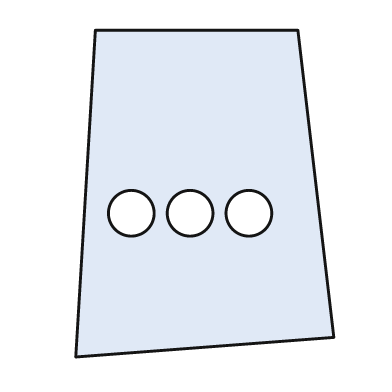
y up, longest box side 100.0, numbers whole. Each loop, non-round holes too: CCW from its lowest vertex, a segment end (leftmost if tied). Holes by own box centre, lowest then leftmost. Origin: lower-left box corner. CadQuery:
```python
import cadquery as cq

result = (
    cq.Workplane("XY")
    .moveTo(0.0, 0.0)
    .lineTo(79.0, 6.0)
    .lineTo(68.0, 100.0)
    .lineTo(6.0, 100.0)
    .close()
    .moveTo(17.0, 44.0)
    .circle(7.0)
    .moveTo(35.0, 44.0)
    .circle(7.0)
    .moveTo(53.0, 44.0)
    .circle(7.0)
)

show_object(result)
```